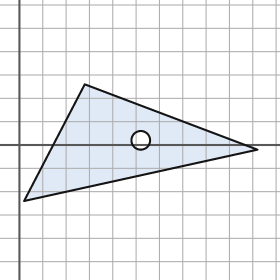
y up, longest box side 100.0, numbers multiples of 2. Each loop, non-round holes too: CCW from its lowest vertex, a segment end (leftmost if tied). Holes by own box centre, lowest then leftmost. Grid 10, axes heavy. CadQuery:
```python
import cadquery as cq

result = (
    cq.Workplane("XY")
    .moveTo(2.0, -24.0)
    .lineTo(102.0, -2.0)
    .lineTo(28.0, 26.0)
    .close()
    .moveTo(52.0, 2.0)
    .circle(4.0)
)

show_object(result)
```